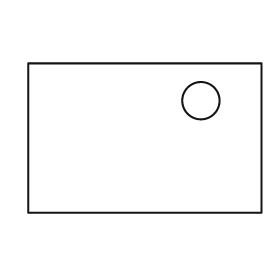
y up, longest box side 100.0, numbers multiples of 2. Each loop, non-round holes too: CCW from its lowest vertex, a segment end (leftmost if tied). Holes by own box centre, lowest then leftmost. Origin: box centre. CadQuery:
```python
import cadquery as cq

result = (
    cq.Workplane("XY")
    .moveTo(-50.0, -32.0)
    .lineTo(50.0, -32.0)
    .lineTo(50.0, 32.0)
    .lineTo(-50.0, 32.0)
    .close()
    .moveTo(24.0, 16.0)
    .circle(8.0)
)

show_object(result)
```